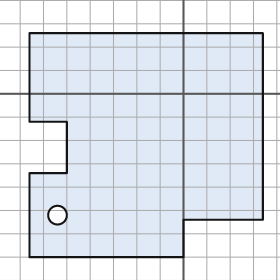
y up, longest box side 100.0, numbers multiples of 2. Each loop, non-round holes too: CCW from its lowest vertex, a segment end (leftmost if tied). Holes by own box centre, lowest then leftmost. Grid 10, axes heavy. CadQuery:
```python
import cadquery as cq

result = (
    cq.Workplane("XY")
    .moveTo(-66.0, -70.0)
    .lineTo(0.0, -70.0)
    .lineTo(0.0, -54.0)
    .lineTo(34.0, -54.0)
    .lineTo(34.0, 26.0)
    .lineTo(-66.0, 26.0)
    .lineTo(-66.0, -12.0)
    .lineTo(-50.0, -12.0)
    .lineTo(-50.0, -34.0)
    .lineTo(-66.0, -34.0)
    .close()
    .moveTo(-54.0, -52.0)
    .circle(4.0)
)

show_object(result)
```